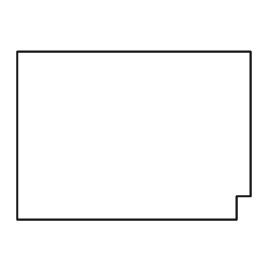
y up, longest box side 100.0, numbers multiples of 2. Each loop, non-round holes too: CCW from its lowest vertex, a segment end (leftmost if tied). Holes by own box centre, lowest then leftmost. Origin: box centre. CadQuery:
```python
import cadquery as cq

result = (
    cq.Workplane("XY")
    .moveTo(-50.0, -36.0)
    .lineTo(44.0, -36.0)
    .lineTo(44.0, -26.0)
    .lineTo(50.0, -26.0)
    .lineTo(50.0, 36.0)
    .lineTo(-50.0, 36.0)
    .close()
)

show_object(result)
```